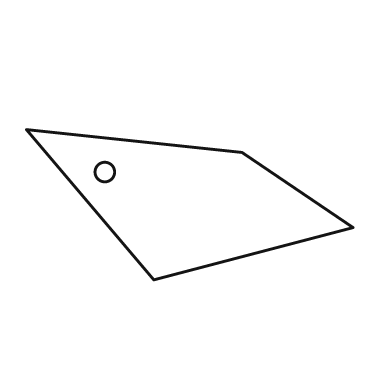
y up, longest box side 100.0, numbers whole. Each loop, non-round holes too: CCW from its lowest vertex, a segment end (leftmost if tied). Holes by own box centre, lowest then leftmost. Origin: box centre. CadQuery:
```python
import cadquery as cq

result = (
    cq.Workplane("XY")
    .moveTo(-11.0, -23.0)
    .lineTo(50.0, -7.0)
    .lineTo(16.0, 16.0)
    .lineTo(-50.0, 23.0)
    .close()
    .moveTo(-26.0, 10.0)
    .circle(3.0)
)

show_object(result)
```